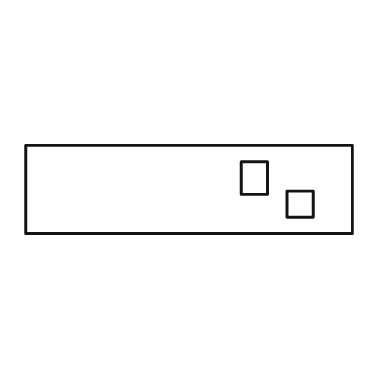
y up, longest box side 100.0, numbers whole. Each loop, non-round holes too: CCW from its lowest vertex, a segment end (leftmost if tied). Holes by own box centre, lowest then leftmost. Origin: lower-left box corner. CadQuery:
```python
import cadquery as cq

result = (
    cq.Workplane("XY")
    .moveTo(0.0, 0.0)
    .lineTo(100.0, 0.0)
    .lineTo(100.0, 27.0)
    .lineTo(0.0, 27.0)
    .close()
    .moveTo(80.0, 5.0)
    .lineTo(88.0, 5.0)
    .lineTo(88.0, 13.0)
    .lineTo(80.0, 13.0)
    .close()
    .moveTo(66.0, 12.0)
    .lineTo(74.0, 12.0)
    .lineTo(74.0, 22.0)
    .lineTo(66.0, 22.0)
    .close()
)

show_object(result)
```